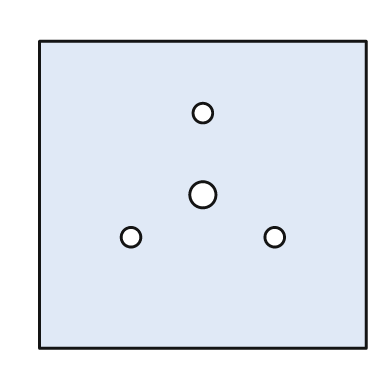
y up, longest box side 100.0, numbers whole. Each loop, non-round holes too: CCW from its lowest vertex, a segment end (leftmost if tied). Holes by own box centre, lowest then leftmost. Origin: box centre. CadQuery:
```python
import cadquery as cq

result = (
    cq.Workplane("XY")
    .moveTo(-50.0, -47.0)
    .lineTo(50.0, -47.0)
    .lineTo(50.0, 47.0)
    .lineTo(-50.0, 47.0)
    .close()
    .moveTo(-22.0, -13.0)
    .circle(3.0)
    .moveTo(22.0, -13.0)
    .circle(3.0)
    .moveTo(0.0, 0.0)
    .circle(4.0)
    .moveTo(0.0, 25.0)
    .circle(3.0)
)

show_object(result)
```